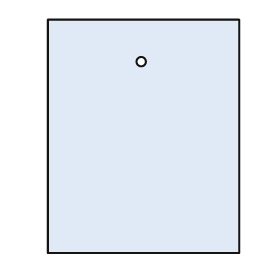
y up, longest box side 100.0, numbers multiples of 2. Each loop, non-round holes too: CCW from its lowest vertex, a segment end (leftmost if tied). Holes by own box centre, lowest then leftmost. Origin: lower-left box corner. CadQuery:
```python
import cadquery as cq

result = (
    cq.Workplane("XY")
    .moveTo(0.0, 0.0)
    .lineTo(82.0, 0.0)
    .lineTo(82.0, 100.0)
    .lineTo(0.0, 100.0)
    .close()
    .moveTo(40.0, 82.0)
    .circle(2.0)
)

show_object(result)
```